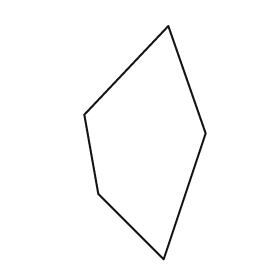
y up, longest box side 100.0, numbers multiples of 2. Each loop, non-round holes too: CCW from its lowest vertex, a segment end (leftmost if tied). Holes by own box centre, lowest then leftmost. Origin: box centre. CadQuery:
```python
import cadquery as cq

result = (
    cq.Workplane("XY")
    .moveTo(8.0, -50.0)
    .lineTo(26.0, 4.0)
    .lineTo(10.0, 50.0)
    .lineTo(-26.0, 12.0)
    .lineTo(-20.0, -22.0)
    .close()
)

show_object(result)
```